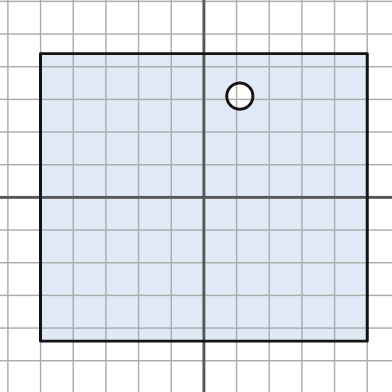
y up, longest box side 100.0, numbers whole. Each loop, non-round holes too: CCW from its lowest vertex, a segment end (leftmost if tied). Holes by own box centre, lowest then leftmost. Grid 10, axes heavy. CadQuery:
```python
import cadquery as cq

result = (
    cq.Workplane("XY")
    .moveTo(-50.0, -44.0)
    .lineTo(50.0, -44.0)
    .lineTo(50.0, 44.0)
    .lineTo(-50.0, 44.0)
    .close()
    .moveTo(11.0, 31.0)
    .circle(4.0)
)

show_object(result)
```